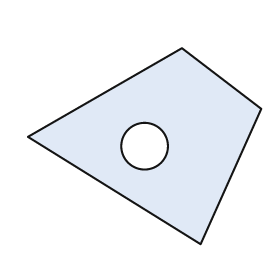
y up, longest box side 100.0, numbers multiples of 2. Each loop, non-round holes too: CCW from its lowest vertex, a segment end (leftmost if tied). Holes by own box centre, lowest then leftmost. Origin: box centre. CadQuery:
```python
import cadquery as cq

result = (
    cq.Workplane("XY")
    .moveTo(24.0, -42.0)
    .lineTo(50.0, 16.0)
    .lineTo(16.0, 42.0)
    .lineTo(-50.0, 4.0)
    .close()
    .moveTo(0.0, 0.0)
    .circle(10.0)
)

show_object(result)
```